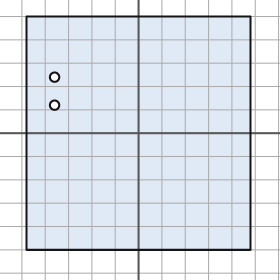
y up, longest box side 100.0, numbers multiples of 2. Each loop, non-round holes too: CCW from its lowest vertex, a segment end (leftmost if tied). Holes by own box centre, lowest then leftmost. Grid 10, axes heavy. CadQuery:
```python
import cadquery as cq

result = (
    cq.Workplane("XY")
    .moveTo(-48.0, -50.0)
    .lineTo(48.0, -50.0)
    .lineTo(48.0, 50.0)
    .lineTo(-48.0, 50.0)
    .close()
    .moveTo(-36.0, 12.0)
    .circle(2.0)
    .moveTo(-36.0, 24.0)
    .circle(2.0)
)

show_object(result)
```